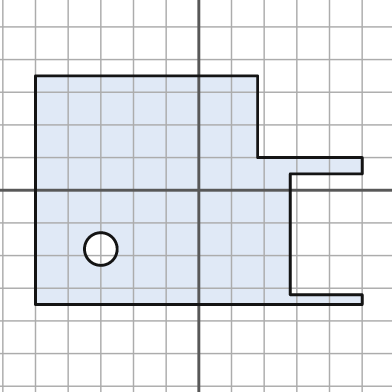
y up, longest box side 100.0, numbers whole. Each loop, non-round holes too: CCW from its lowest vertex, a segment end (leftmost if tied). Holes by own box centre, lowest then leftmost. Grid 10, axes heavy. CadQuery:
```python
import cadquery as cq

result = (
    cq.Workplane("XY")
    .moveTo(-50.0, -35.0)
    .lineTo(50.0, -35.0)
    .lineTo(50.0, -32.0)
    .lineTo(28.0, -32.0)
    .lineTo(28.0, 5.0)
    .lineTo(50.0, 5.0)
    .lineTo(50.0, 10.0)
    .lineTo(18.0, 10.0)
    .lineTo(18.0, 35.0)
    .lineTo(-50.0, 35.0)
    .close()
    .moveTo(-30.0, -18.0)
    .circle(5.0)
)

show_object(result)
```